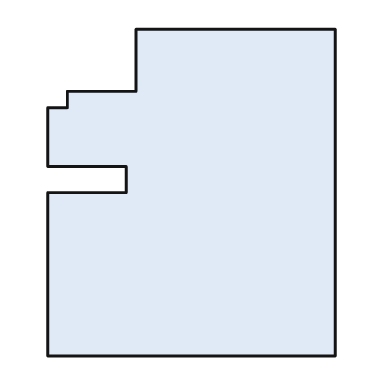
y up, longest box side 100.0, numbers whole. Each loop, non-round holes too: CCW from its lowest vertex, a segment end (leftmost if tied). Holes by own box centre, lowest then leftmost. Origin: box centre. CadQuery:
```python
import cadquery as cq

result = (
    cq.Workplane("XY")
    .moveTo(-44.0, -50.0)
    .lineTo(44.0, -50.0)
    .lineTo(44.0, 50.0)
    .lineTo(-17.0, 50.0)
    .lineTo(-17.0, 31.0)
    .lineTo(-38.0, 31.0)
    .lineTo(-38.0, 26.0)
    .lineTo(-44.0, 26.0)
    .lineTo(-44.0, 8.0)
    .lineTo(-20.0, 8.0)
    .lineTo(-20.0, 0.0)
    .lineTo(-44.0, 0.0)
    .close()
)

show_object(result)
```